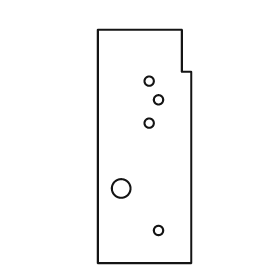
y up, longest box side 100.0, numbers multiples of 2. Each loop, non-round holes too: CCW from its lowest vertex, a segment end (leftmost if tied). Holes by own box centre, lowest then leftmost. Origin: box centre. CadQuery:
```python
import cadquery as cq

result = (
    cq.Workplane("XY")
    .moveTo(-20.0, -50.0)
    .lineTo(20.0, -50.0)
    .lineTo(20.0, 32.0)
    .lineTo(16.0, 32.0)
    .lineTo(16.0, 50.0)
    .lineTo(-20.0, 50.0)
    .close()
    .moveTo(6.0, -36.0)
    .circle(2.0)
    .moveTo(-10.0, -18.0)
    .circle(4.0)
    .moveTo(2.0, 10.0)
    .circle(2.0)
    .moveTo(6.0, 20.0)
    .circle(2.0)
    .moveTo(2.0, 28.0)
    .circle(2.0)
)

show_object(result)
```